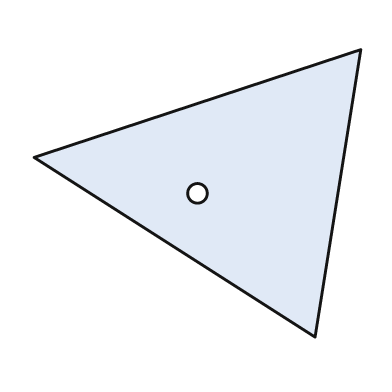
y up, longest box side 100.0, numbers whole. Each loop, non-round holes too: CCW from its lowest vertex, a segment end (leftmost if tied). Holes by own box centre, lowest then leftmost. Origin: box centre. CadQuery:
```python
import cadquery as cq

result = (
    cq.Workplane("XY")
    .moveTo(36.0, -44.0)
    .lineTo(50.0, 44.0)
    .lineTo(-50.0, 11.0)
    .close()
    .moveTo(0.0, 0.0)
    .circle(3.0)
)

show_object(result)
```